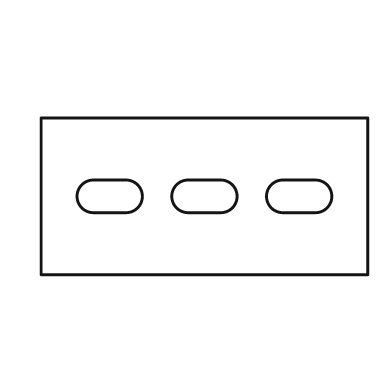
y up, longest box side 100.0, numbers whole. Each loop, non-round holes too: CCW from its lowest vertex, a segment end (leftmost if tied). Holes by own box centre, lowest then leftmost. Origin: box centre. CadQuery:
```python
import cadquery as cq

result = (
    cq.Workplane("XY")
    .moveTo(-50.0, -24.0)
    .lineTo(50.0, -24.0)
    .lineTo(50.0, 24.0)
    .lineTo(-50.0, 24.0)
    .close()
    .moveTo(-34.0, -5.0)
    .lineTo(-24.0, -5.0)
    .threePointArc((-19.0, 0.0), (-24.0, 5.0))
    .lineTo(-34.0, 5.0)
    .threePointArc((-39.0, 0.0), (-34.0, -5.0))
    .close()
    .moveTo(-5.0, -5.0)
    .lineTo(5.0, -5.0)
    .threePointArc((10.0, 0.0), (5.0, 5.0))
    .lineTo(-5.0, 5.0)
    .threePointArc((-10.0, 0.0), (-5.0, -5.0))
    .close()
    .moveTo(24.0, -5.0)
    .lineTo(34.0, -5.0)
    .threePointArc((39.0, 0.0), (34.0, 5.0))
    .lineTo(24.0, 5.0)
    .threePointArc((19.0, 0.0), (24.0, -5.0))
    .close()
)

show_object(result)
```